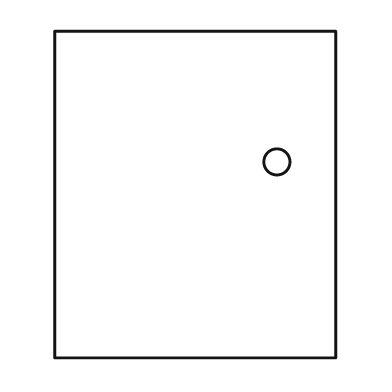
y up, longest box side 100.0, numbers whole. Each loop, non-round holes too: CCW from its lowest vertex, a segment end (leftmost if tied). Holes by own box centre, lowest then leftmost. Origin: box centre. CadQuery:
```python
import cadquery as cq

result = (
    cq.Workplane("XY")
    .moveTo(-43.0, -50.0)
    .lineTo(43.0, -50.0)
    .lineTo(43.0, 50.0)
    .lineTo(-43.0, 50.0)
    .close()
    .moveTo(25.0, 10.0)
    .circle(4.0)
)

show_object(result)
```